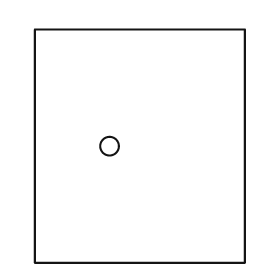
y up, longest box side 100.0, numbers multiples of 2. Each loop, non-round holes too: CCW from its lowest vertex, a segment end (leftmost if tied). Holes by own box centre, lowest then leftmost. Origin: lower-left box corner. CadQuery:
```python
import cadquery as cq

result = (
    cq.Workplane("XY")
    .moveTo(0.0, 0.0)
    .lineTo(90.0, 0.0)
    .lineTo(90.0, 100.0)
    .lineTo(0.0, 100.0)
    .close()
    .moveTo(32.0, 50.0)
    .circle(4.0)
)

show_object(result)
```